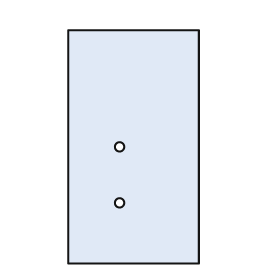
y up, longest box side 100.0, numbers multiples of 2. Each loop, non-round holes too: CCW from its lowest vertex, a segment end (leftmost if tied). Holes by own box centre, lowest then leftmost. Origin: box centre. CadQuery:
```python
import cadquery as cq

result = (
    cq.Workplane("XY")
    .moveTo(-28.0, -50.0)
    .lineTo(28.0, -50.0)
    .lineTo(28.0, 50.0)
    .lineTo(-28.0, 50.0)
    .close()
    .moveTo(-6.0, -24.0)
    .circle(2.0)
    .moveTo(-6.0, 0.0)
    .circle(2.0)
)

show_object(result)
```